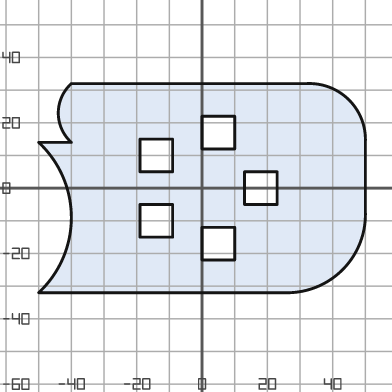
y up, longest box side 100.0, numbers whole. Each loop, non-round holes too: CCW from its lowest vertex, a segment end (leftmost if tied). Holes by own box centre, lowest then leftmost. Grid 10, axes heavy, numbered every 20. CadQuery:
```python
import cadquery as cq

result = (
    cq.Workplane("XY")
    .moveTo(-50.0, -32.0)
    .lineTo(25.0, -32.0)
    .threePointArc((43.0, -25.0), (50.0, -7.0))
    .lineTo(50.0, 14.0)
    .threePointArc((45.0, 27.0), (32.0, 32.0))
    .lineTo(-40.0, 32.0)
    .threePointArc((-44.0, 23.0), (-40.0, 14.0))
    .lineTo(-50.0, 14.0)
    .threePointArc((-40.0, -9.0), (-50.0, -32.0))
    .close()
    .moveTo(0.0, -22.0)
    .lineTo(10.0, -22.0)
    .lineTo(10.0, -12.0)
    .lineTo(0.0, -12.0)
    .close()
    .moveTo(-19.0, -15.0)
    .lineTo(-9.0, -15.0)
    .lineTo(-9.0, -5.0)
    .lineTo(-19.0, -5.0)
    .close()
    .moveTo(13.0, -5.0)
    .lineTo(23.0, -5.0)
    .lineTo(23.0, 5.0)
    .lineTo(13.0, 5.0)
    .close()
    .moveTo(-19.0, 5.0)
    .lineTo(-9.0, 5.0)
    .lineTo(-9.0, 15.0)
    .lineTo(-19.0, 15.0)
    .close()
    .moveTo(0.0, 12.0)
    .lineTo(10.0, 12.0)
    .lineTo(10.0, 22.0)
    .lineTo(0.0, 22.0)
    .close()
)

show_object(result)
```